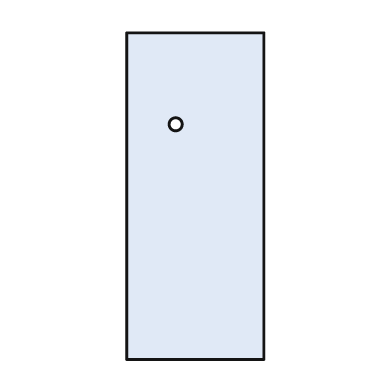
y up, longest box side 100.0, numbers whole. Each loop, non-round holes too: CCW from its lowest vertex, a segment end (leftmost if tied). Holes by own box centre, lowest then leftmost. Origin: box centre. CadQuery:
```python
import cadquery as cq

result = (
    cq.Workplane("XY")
    .moveTo(-21.0, -50.0)
    .lineTo(21.0, -50.0)
    .lineTo(21.0, 50.0)
    .lineTo(-21.0, 50.0)
    .close()
    .moveTo(-6.0, 22.0)
    .circle(2.0)
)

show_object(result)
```